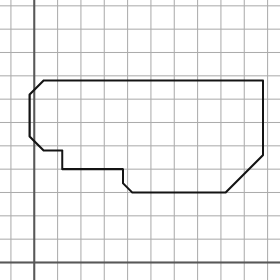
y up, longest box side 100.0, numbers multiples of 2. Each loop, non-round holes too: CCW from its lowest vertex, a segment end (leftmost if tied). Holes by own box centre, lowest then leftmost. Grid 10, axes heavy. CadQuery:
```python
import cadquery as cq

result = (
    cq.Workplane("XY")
    .moveTo(42.0, 30.0)
    .lineTo(82.0, 30.0)
    .lineTo(98.0, 46.0)
    .lineTo(98.0, 78.0)
    .lineTo(4.0, 78.0)
    .lineTo(-2.0, 72.0)
    .lineTo(-2.0, 54.0)
    .lineTo(4.0, 48.0)
    .lineTo(12.0, 48.0)
    .lineTo(12.0, 40.0)
    .lineTo(38.0, 40.0)
    .lineTo(38.0, 34.0)
    .close()
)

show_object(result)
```